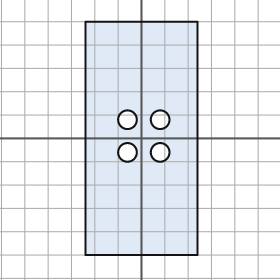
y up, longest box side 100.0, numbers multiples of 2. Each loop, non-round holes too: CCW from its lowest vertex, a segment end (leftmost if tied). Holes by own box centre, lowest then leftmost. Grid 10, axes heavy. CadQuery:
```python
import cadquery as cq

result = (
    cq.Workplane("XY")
    .moveTo(-24.0, -50.0)
    .lineTo(24.0, -50.0)
    .lineTo(24.0, 50.0)
    .lineTo(-24.0, 50.0)
    .close()
    .moveTo(-6.0, -6.0)
    .circle(4.0)
    .moveTo(8.0, -6.0)
    .circle(4.0)
    .moveTo(-6.0, 8.0)
    .circle(4.0)
    .moveTo(8.0, 8.0)
    .circle(4.0)
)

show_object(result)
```